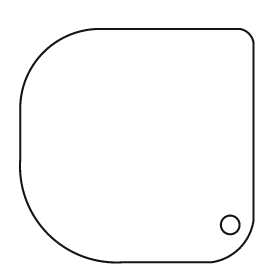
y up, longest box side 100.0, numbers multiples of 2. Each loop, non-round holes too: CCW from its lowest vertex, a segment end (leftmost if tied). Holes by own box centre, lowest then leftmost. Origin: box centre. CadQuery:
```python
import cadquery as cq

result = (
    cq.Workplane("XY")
    .moveTo(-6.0, -50.0)
    .lineTo(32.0, -50.0)
    .threePointArc((44.0, -44.0), (50.0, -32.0))
    .lineTo(50.0, 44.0)
    .threePointArc((48.0, 48.0), (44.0, 50.0))
    .lineTo(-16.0, 50.0)
    .threePointArc((-40.0, 40.0), (-50.0, 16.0))
    .lineTo(-50.0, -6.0)
    .threePointArc((-38.0, -38.0), (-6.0, -50.0))
    .close()
    .moveTo(40.0, -34.0)
    .circle(4.0)
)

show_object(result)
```